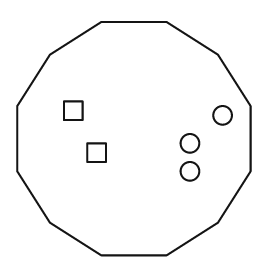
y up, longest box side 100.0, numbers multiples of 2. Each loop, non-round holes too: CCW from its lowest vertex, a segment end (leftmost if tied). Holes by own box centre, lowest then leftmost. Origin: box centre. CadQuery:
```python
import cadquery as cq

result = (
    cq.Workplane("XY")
    .moveTo(-14.0, -50.0)
    .lineTo(14.0, -50.0)
    .lineTo(36.0, -36.0)
    .lineTo(50.0, -14.0)
    .lineTo(50.0, 14.0)
    .lineTo(36.0, 36.0)
    .lineTo(14.0, 50.0)
    .lineTo(-14.0, 50.0)
    .lineTo(-36.0, 36.0)
    .lineTo(-50.0, 14.0)
    .lineTo(-50.0, -14.0)
    .lineTo(-36.0, -36.0)
    .close()
    .moveTo(24.0, -14.0)
    .circle(4.0)
    .moveTo(-20.0, -10.0)
    .lineTo(-12.0, -10.0)
    .lineTo(-12.0, -2.0)
    .lineTo(-20.0, -2.0)
    .close()
    .moveTo(24.0, -2.0)
    .circle(4.0)
    .moveTo(38.0, 10.0)
    .circle(4.0)
    .moveTo(-30.0, 8.0)
    .lineTo(-22.0, 8.0)
    .lineTo(-22.0, 16.0)
    .lineTo(-30.0, 16.0)
    .close()
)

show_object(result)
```